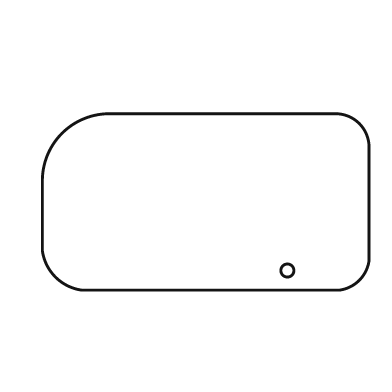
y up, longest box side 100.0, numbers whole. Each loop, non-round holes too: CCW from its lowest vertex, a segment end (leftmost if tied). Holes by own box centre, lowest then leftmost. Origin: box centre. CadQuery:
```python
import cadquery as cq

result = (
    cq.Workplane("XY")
    .moveTo(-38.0, -27.0)
    .lineTo(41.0, -27.0)
    .threePointArc((47.0, -24.0), (50.0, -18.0))
    .lineTo(50.0, 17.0)
    .threePointArc((47.0, 24.0), (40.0, 27.0))
    .lineTo(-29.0, 27.0)
    .threePointArc((-44.0, 21.0), (-50.0, 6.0))
    .lineTo(-50.0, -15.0)
    .threePointArc((-46.0, -23.0), (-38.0, -27.0))
    .close()
    .moveTo(25.0, -21.0)
    .circle(2.0)
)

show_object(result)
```